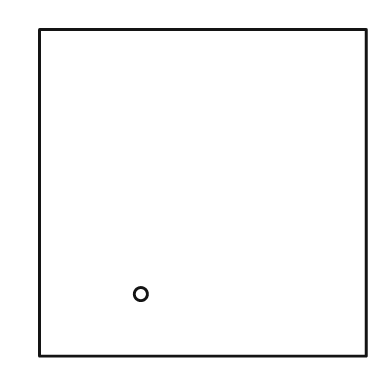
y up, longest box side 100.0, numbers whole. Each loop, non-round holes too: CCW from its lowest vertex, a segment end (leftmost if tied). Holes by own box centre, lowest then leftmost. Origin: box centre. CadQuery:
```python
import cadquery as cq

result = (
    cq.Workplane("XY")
    .moveTo(-50.0, -50.0)
    .lineTo(50.0, -50.0)
    .lineTo(50.0, 50.0)
    .lineTo(-50.0, 50.0)
    .close()
    .moveTo(-19.0, -31.0)
    .circle(2.0)
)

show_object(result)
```